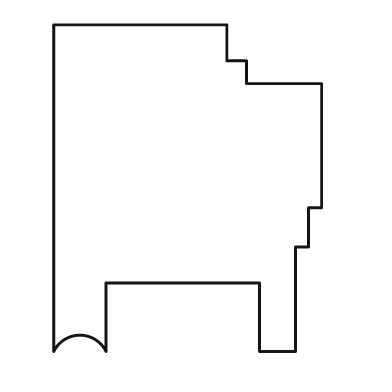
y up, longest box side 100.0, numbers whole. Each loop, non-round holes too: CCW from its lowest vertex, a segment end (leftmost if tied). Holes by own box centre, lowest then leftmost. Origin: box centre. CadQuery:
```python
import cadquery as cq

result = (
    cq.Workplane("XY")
    .moveTo(-41.0, -50.0)
    .threePointArc((-33.0, -45.0), (-25.0, -50.0))
    .lineTo(-25.0, -29.0)
    .lineTo(22.0, -29.0)
    .lineTo(22.0, -50.0)
    .lineTo(33.0, -50.0)
    .lineTo(33.0, -18.0)
    .lineTo(37.0, -18.0)
    .lineTo(37.0, -6.0)
    .lineTo(41.0, -6.0)
    .lineTo(41.0, 32.0)
    .lineTo(18.0, 32.0)
    .lineTo(18.0, 39.0)
    .lineTo(12.0, 39.0)
    .lineTo(12.0, 50.0)
    .lineTo(-41.0, 50.0)
    .close()
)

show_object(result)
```